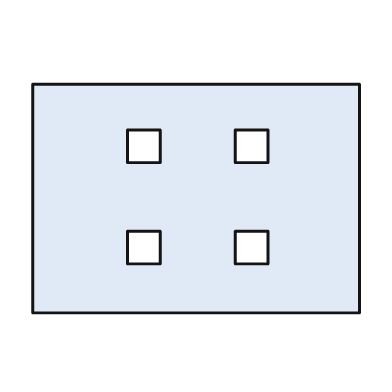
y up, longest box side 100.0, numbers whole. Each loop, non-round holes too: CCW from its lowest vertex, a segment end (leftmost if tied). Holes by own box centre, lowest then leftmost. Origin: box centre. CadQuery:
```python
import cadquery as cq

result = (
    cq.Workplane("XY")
    .moveTo(-50.0, -35.0)
    .lineTo(50.0, -35.0)
    .lineTo(50.0, 35.0)
    .lineTo(-50.0, 35.0)
    .close()
    .moveTo(-21.0, -20.0)
    .lineTo(-11.0, -20.0)
    .lineTo(-11.0, -10.0)
    .lineTo(-21.0, -10.0)
    .close()
    .moveTo(12.0, -20.0)
    .lineTo(22.0, -20.0)
    .lineTo(22.0, -10.0)
    .lineTo(12.0, -10.0)
    .close()
    .moveTo(-21.0, 11.0)
    .lineTo(-11.0, 11.0)
    .lineTo(-11.0, 21.0)
    .lineTo(-21.0, 21.0)
    .close()
    .moveTo(12.0, 11.0)
    .lineTo(22.0, 11.0)
    .lineTo(22.0, 21.0)
    .lineTo(12.0, 21.0)
    .close()
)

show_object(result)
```